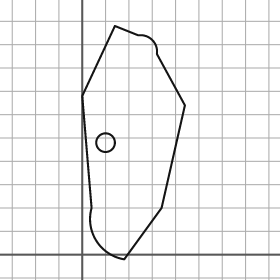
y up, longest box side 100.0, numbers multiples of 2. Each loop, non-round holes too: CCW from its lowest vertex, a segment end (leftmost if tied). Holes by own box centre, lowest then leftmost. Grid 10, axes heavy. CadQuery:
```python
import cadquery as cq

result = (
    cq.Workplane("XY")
    .moveTo(18.0, -2.0)
    .lineTo(34.0, 20.0)
    .lineTo(44.0, 64.0)
    .lineTo(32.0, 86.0)
    .threePointArc((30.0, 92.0), (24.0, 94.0))
    .lineTo(14.0, 98.0)
    .lineTo(0.0, 68.0)
    .lineTo(4.0, 20.0)
    .threePointArc((6.0, 6.0), (18.0, -2.0))
    .close()
    .moveTo(10.0, 48.0)
    .circle(4.0)
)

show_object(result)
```